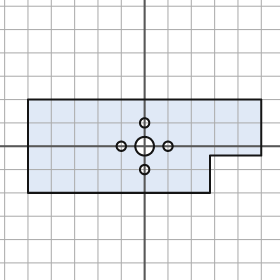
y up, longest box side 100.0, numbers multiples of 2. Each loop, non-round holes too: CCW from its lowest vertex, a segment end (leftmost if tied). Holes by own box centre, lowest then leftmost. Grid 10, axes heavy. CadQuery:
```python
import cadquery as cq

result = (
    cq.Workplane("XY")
    .moveTo(-50.0, -20.0)
    .lineTo(28.0, -20.0)
    .lineTo(28.0, -4.0)
    .lineTo(50.0, -4.0)
    .lineTo(50.0, 20.0)
    .lineTo(-50.0, 20.0)
    .close()
    .moveTo(0.0, -10.0)
    .circle(2.0)
    .moveTo(-10.0, 0.0)
    .circle(2.0)
    .moveTo(0.0, 0.0)
    .circle(4.0)
    .moveTo(10.0, 0.0)
    .circle(2.0)
    .moveTo(0.0, 10.0)
    .circle(2.0)
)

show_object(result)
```